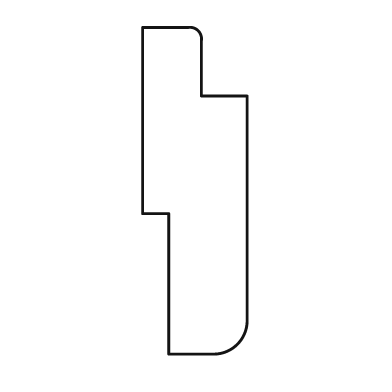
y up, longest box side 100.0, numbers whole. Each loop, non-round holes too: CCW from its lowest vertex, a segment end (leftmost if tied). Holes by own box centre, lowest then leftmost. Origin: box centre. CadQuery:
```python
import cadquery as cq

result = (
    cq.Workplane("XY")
    .moveTo(-8.0, -50.0)
    .lineTo(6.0, -50.0)
    .threePointArc((13.0, -47.0), (16.0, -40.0))
    .lineTo(16.0, 29.0)
    .lineTo(2.0, 29.0)
    .lineTo(2.0, 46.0)
    .threePointArc((1.0, 49.0), (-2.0, 50.0))
    .lineTo(-16.0, 50.0)
    .lineTo(-16.0, -7.0)
    .lineTo(-8.0, -7.0)
    .close()
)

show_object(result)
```